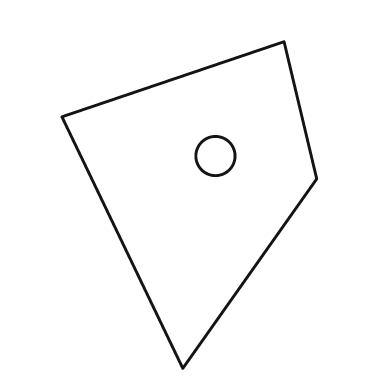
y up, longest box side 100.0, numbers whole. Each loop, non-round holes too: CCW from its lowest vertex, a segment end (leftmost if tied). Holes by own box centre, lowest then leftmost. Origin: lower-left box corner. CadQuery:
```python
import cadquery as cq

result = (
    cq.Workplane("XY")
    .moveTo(37.0, 0.0)
    .lineTo(78.0, 58.0)
    .lineTo(68.0, 100.0)
    .lineTo(0.0, 77.0)
    .close()
    .moveTo(47.0, 65.0)
    .circle(6.0)
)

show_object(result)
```